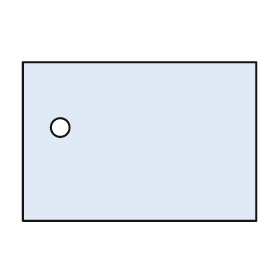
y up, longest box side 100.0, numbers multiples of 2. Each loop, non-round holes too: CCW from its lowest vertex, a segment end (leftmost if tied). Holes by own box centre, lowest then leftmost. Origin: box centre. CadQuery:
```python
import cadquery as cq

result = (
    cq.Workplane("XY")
    .moveTo(-50.0, -34.0)
    .lineTo(50.0, -34.0)
    .lineTo(50.0, 34.0)
    .lineTo(-50.0, 34.0)
    .close()
    .moveTo(-34.0, 6.0)
    .circle(4.0)
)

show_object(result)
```